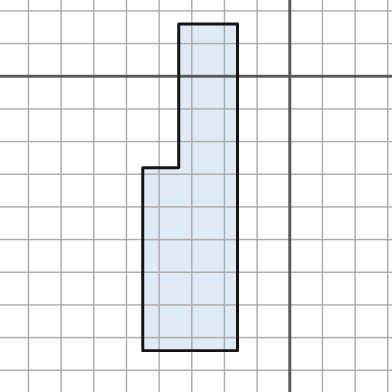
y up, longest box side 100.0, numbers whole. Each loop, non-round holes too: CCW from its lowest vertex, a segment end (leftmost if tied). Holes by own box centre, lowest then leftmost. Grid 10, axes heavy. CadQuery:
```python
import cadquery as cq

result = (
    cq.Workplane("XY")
    .moveTo(-45.0, -84.0)
    .lineTo(-16.0, -84.0)
    .lineTo(-16.0, 16.0)
    .lineTo(-34.0, 16.0)
    .lineTo(-34.0, -28.0)
    .lineTo(-45.0, -28.0)
    .close()
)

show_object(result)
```